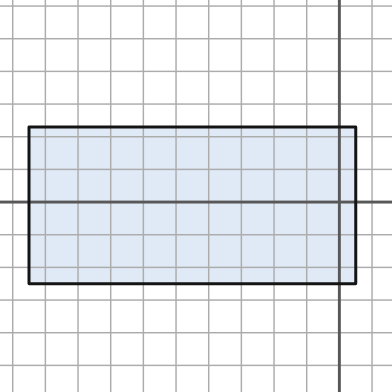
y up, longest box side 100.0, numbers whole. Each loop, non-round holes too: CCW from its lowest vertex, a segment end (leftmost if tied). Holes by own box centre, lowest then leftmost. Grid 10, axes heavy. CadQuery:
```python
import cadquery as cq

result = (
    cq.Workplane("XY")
    .moveTo(-95.0, -25.0)
    .lineTo(5.0, -25.0)
    .lineTo(5.0, 23.0)
    .lineTo(-95.0, 23.0)
    .close()
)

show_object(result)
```